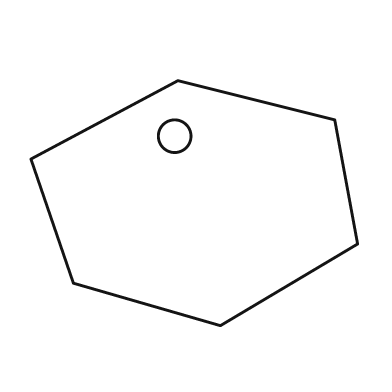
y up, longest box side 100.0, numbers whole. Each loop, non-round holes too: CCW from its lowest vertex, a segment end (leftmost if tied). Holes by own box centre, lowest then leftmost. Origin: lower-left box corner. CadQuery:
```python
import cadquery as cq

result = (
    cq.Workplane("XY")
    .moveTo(58.0, 0.0)
    .lineTo(100.0, 25.0)
    .lineTo(93.0, 63.0)
    .lineTo(45.0, 75.0)
    .lineTo(0.0, 51.0)
    .lineTo(13.0, 13.0)
    .close()
    .moveTo(44.0, 58.0)
    .circle(5.0)
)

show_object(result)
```